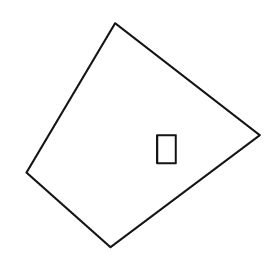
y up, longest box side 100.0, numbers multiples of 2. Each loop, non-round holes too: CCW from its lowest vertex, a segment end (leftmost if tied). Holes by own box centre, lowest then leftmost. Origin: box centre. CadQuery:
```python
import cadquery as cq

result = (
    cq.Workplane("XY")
    .moveTo(-14.0, -48.0)
    .lineTo(50.0, 0.0)
    .lineTo(-12.0, 48.0)
    .lineTo(-50.0, -16.0)
    .close()
    .moveTo(6.0, -12.0)
    .lineTo(14.0, -12.0)
    .lineTo(14.0, 0.0)
    .lineTo(6.0, 0.0)
    .close()
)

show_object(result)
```